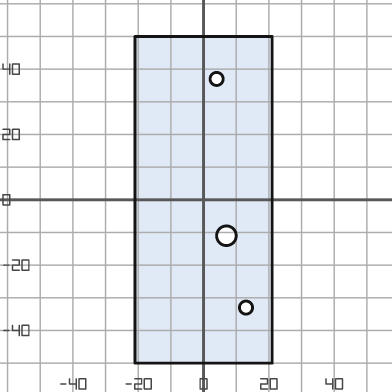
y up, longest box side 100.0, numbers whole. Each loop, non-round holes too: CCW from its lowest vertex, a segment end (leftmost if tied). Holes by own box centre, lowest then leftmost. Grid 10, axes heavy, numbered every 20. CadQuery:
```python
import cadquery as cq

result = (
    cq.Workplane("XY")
    .moveTo(-21.0, -50.0)
    .lineTo(21.0, -50.0)
    .lineTo(21.0, 50.0)
    .lineTo(-21.0, 50.0)
    .close()
    .moveTo(13.0, -33.0)
    .circle(2.0)
    .moveTo(7.0, -11.0)
    .circle(3.0)
    .moveTo(4.0, 37.0)
    .circle(2.0)
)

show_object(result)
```